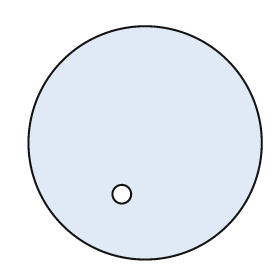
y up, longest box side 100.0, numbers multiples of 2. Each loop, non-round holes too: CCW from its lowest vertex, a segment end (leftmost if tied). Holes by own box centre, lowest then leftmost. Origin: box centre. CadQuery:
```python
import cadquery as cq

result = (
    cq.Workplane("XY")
    .moveTo(0.0, 0.0)
    .circle(50.0)
    .moveTo(-10.0, -22.0)
    .circle(4.0)
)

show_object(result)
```